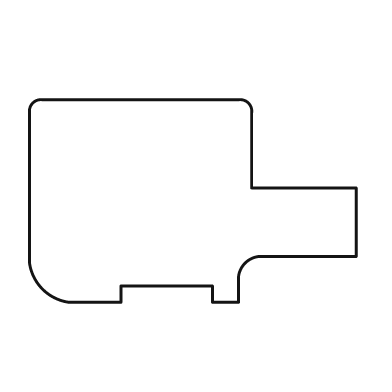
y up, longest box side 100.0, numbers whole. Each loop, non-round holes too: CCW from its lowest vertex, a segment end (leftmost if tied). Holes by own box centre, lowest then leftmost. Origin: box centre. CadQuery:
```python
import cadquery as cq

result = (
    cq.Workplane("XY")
    .moveTo(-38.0, -31.0)
    .lineTo(-22.0, -31.0)
    .lineTo(-22.0, -26.0)
    .lineTo(6.0, -26.0)
    .lineTo(6.0, -31.0)
    .lineTo(14.0, -31.0)
    .lineTo(14.0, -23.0)
    .threePointArc((16.0, -19.0), (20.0, -17.0))
    .lineTo(50.0, -17.0)
    .lineTo(50.0, 4.0)
    .lineTo(18.0, 4.0)
    .lineTo(18.0, 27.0)
    .threePointArc((17.0, 30.0), (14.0, 31.0))
    .lineTo(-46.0, 31.0)
    .threePointArc((-49.0, 30.0), (-50.0, 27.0))
    .lineTo(-50.0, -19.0)
    .threePointArc((-46.0, -27.0), (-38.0, -31.0))
    .close()
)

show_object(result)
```